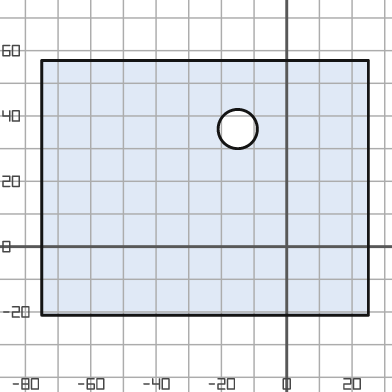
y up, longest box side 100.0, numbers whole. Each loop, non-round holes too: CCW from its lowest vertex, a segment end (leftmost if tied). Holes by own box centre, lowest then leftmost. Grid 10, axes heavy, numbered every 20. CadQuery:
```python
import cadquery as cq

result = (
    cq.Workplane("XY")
    .moveTo(-75.0, -21.0)
    .lineTo(25.0, -21.0)
    .lineTo(25.0, 57.0)
    .lineTo(-75.0, 57.0)
    .close()
    .moveTo(-15.0, 36.0)
    .circle(6.0)
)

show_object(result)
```